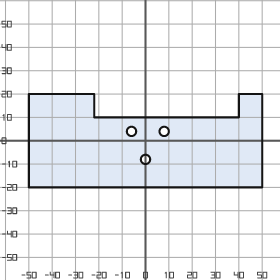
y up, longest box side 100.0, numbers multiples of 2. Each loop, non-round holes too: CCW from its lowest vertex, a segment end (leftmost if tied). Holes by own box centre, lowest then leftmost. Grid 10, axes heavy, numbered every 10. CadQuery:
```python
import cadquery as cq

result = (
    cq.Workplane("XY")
    .moveTo(-50.0, -20.0)
    .lineTo(50.0, -20.0)
    .lineTo(50.0, 20.0)
    .lineTo(40.0, 20.0)
    .lineTo(40.0, 10.0)
    .lineTo(-22.0, 10.0)
    .lineTo(-22.0, 20.0)
    .lineTo(-50.0, 20.0)
    .close()
    .moveTo(0.0, -8.0)
    .circle(2.0)
    .moveTo(-6.0, 4.0)
    .circle(2.0)
    .moveTo(8.0, 4.0)
    .circle(2.0)
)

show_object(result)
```